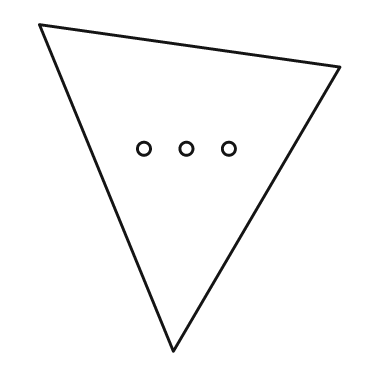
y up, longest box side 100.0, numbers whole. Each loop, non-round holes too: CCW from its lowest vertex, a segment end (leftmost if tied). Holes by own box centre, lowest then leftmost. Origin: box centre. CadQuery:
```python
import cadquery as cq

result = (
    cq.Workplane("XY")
    .moveTo(-5.0, -50.0)
    .lineTo(46.0, 37.0)
    .lineTo(-46.0, 50.0)
    .close()
    .moveTo(-14.0, 12.0)
    .circle(2.0)
    .moveTo(-1.0, 12.0)
    .circle(2.0)
    .moveTo(12.0, 12.0)
    .circle(2.0)
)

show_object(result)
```